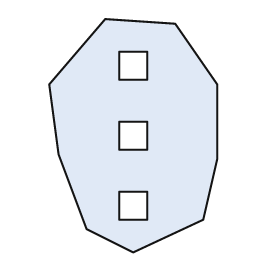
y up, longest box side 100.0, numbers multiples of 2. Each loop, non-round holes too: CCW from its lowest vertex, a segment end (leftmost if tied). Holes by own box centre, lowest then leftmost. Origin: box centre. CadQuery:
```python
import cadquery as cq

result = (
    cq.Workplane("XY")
    .moveTo(0.0, -50.0)
    .lineTo(30.0, -36.0)
    .lineTo(36.0, -10.0)
    .lineTo(36.0, 22.0)
    .lineTo(18.0, 48.0)
    .lineTo(-12.0, 50.0)
    .lineTo(-36.0, 22.0)
    .lineTo(-32.0, -8.0)
    .lineTo(-20.0, -40.0)
    .close()
    .moveTo(-6.0, -36.0)
    .lineTo(6.0, -36.0)
    .lineTo(6.0, -24.0)
    .lineTo(-6.0, -24.0)
    .close()
    .moveTo(-6.0, -6.0)
    .lineTo(6.0, -6.0)
    .lineTo(6.0, 6.0)
    .lineTo(-6.0, 6.0)
    .close()
    .moveTo(-6.0, 24.0)
    .lineTo(6.0, 24.0)
    .lineTo(6.0, 36.0)
    .lineTo(-6.0, 36.0)
    .close()
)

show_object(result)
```